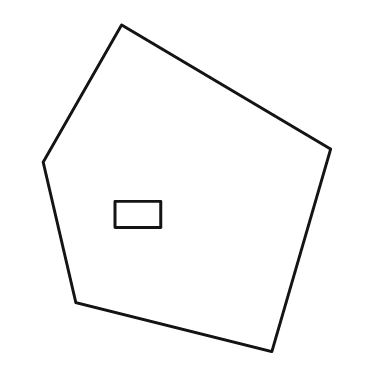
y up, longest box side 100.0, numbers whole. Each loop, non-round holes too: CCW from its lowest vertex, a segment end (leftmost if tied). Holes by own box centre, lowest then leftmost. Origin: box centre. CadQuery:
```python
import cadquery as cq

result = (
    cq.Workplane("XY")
    .moveTo(26.0, -50.0)
    .lineTo(44.0, 12.0)
    .lineTo(-20.0, 50.0)
    .lineTo(-44.0, 8.0)
    .lineTo(-34.0, -35.0)
    .close()
    .moveTo(-22.0, -12.0)
    .lineTo(-8.0, -12.0)
    .lineTo(-8.0, -4.0)
    .lineTo(-22.0, -4.0)
    .close()
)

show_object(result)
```